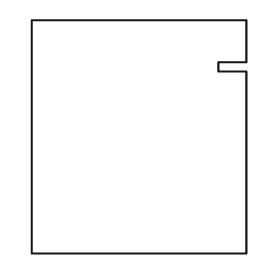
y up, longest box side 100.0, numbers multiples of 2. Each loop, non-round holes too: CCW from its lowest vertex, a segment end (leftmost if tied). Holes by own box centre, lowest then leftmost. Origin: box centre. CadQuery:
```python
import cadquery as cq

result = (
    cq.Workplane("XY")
    .moveTo(-46.0, -50.0)
    .lineTo(46.0, -50.0)
    .lineTo(46.0, 28.0)
    .lineTo(34.0, 28.0)
    .lineTo(34.0, 32.0)
    .lineTo(46.0, 32.0)
    .lineTo(46.0, 50.0)
    .lineTo(-46.0, 50.0)
    .close()
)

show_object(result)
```